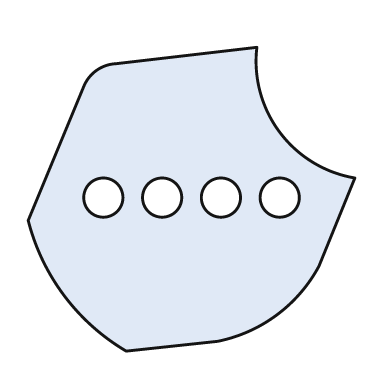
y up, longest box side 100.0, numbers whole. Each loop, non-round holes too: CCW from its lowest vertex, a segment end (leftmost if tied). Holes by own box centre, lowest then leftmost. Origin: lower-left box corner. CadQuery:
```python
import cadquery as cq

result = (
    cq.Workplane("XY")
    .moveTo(30.0, 0.0)
    .lineTo(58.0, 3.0)
    .threePointArc((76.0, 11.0), (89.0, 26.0))
    .lineTo(100.0, 53.0)
    .threePointArc((77.0, 67.0), (70.0, 93.0))
    .lineTo(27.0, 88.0)
    .threePointArc((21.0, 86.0), (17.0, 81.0))
    .lineTo(0.0, 40.0)
    .threePointArc((11.0, 17.0), (30.0, 0.0))
    .close()
    .moveTo(23.0, 47.0)
    .circle(6.0)
    .moveTo(41.0, 47.0)
    .circle(6.0)
    .moveTo(59.0, 47.0)
    .circle(6.0)
    .moveTo(77.0, 47.0)
    .circle(6.0)
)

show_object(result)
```